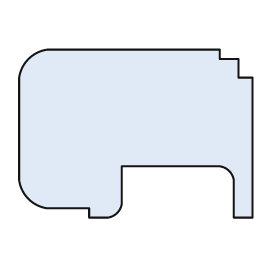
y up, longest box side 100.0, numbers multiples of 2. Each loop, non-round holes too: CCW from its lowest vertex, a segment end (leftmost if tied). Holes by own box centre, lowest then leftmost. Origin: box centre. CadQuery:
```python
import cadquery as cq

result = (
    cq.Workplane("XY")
    .moveTo(-20.0, -36.0)
    .lineTo(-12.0, -36.0)
    .threePointArc((-8.0, -34.0), (-6.0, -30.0))
    .lineTo(-6.0, -14.0)
    .lineTo(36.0, -14.0)
    .threePointArc((40.0, -16.0), (42.0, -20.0))
    .lineTo(42.0, -36.0)
    .lineTo(50.0, -36.0)
    .lineTo(50.0, 24.0)
    .lineTo(44.0, 24.0)
    .lineTo(44.0, 32.0)
    .lineTo(36.0, 32.0)
    .lineTo(36.0, 36.0)
    .lineTo(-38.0, 36.0)
    .threePointArc((-46.0, 32.0), (-50.0, 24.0))
    .lineTo(-50.0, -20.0)
    .threePointArc((-46.0, -28.0), (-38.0, -32.0))
    .lineTo(-20.0, -32.0)
    .close()
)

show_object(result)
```